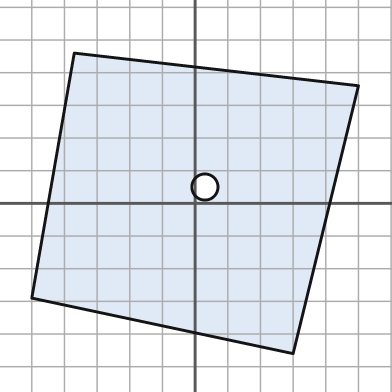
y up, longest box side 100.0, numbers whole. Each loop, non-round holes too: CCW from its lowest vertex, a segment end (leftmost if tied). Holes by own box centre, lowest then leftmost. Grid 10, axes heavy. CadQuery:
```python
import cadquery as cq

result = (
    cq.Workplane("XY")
    .moveTo(30.0, -46.0)
    .lineTo(50.0, 36.0)
    .lineTo(-37.0, 46.0)
    .lineTo(-50.0, -29.0)
    .close()
    .moveTo(3.0, 5.0)
    .circle(4.0)
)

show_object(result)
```